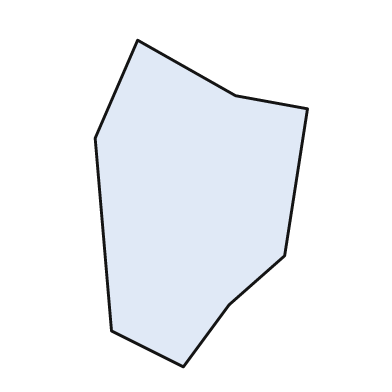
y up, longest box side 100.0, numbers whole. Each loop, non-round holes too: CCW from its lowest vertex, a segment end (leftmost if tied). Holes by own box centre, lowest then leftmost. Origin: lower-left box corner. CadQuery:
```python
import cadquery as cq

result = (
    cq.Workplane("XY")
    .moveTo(27.0, 0.0)
    .lineTo(41.0, 19.0)
    .lineTo(58.0, 34.0)
    .lineTo(65.0, 79.0)
    .lineTo(43.0, 83.0)
    .lineTo(13.0, 100.0)
    .lineTo(0.0, 70.0)
    .lineTo(5.0, 11.0)
    .close()
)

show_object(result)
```